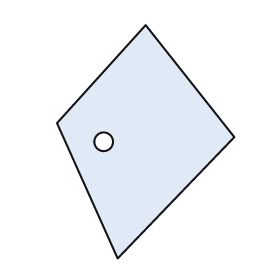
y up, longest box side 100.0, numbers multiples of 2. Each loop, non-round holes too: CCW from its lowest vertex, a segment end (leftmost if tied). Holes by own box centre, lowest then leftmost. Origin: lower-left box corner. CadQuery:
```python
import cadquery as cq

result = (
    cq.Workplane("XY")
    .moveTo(26.0, 0.0)
    .lineTo(76.0, 52.0)
    .lineTo(38.0, 100.0)
    .lineTo(0.0, 58.0)
    .close()
    .moveTo(20.0, 50.0)
    .circle(4.0)
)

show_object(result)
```